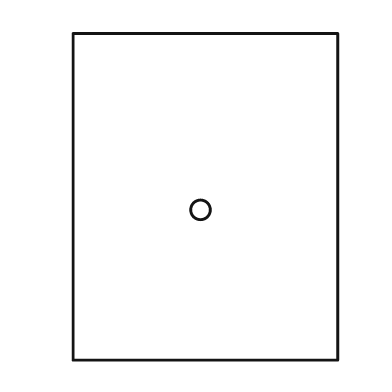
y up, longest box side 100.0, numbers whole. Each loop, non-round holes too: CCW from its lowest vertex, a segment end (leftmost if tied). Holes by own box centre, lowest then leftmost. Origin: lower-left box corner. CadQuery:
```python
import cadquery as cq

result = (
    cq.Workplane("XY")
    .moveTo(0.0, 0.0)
    .lineTo(81.0, 0.0)
    .lineTo(81.0, 100.0)
    .lineTo(0.0, 100.0)
    .close()
    .moveTo(39.0, 46.0)
    .circle(3.0)
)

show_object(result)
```